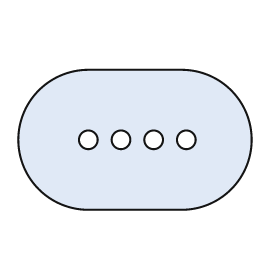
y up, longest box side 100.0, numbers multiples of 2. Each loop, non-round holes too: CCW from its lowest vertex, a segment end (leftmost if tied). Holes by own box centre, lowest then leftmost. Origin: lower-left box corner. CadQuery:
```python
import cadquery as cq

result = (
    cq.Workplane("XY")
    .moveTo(30.0, 0.0)
    .lineTo(70.0, 0.0)
    .threePointArc((100.0, 30.0), (70.0, 60.0))
    .lineTo(30.0, 60.0)
    .threePointArc((0.0, 30.0), (30.0, 0.0))
    .close()
    .moveTo(30.0, 30.0)
    .circle(4.0)
    .moveTo(44.0, 30.0)
    .circle(4.0)
    .moveTo(58.0, 30.0)
    .circle(4.0)
    .moveTo(72.0, 30.0)
    .circle(4.0)
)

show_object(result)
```